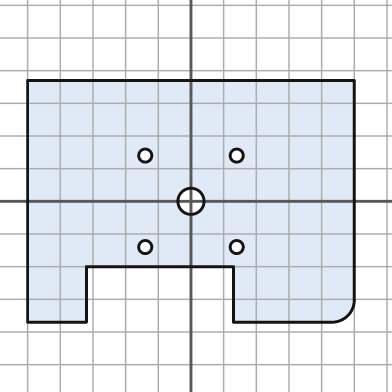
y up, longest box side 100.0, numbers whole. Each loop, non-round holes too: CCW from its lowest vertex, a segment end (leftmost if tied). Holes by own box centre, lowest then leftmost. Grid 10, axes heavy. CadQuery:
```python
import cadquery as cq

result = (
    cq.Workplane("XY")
    .moveTo(-50.0, -37.0)
    .lineTo(-32.0, -37.0)
    .lineTo(-32.0, -20.0)
    .lineTo(13.0, -20.0)
    .lineTo(13.0, -37.0)
    .lineTo(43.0, -37.0)
    .threePointArc((48.0, -35.0), (50.0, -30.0))
    .lineTo(50.0, 37.0)
    .lineTo(-50.0, 37.0)
    .close()
    .moveTo(-14.0, -14.0)
    .circle(2.0)
    .moveTo(14.0, -14.0)
    .circle(2.0)
    .moveTo(0.0, 0.0)
    .circle(4.0)
    .moveTo(-14.0, 14.0)
    .circle(2.0)
    .moveTo(14.0, 14.0)
    .circle(2.0)
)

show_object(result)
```